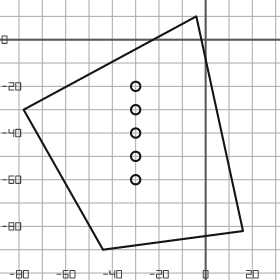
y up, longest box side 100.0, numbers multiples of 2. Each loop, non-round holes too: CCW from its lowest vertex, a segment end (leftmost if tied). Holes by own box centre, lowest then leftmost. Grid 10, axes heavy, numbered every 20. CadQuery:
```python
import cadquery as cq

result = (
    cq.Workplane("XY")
    .moveTo(-44.0, -90.0)
    .lineTo(16.0, -82.0)
    .lineTo(-4.0, 10.0)
    .lineTo(-78.0, -30.0)
    .close()
    .moveTo(-30.0, -60.0)
    .circle(2.0)
    .moveTo(-30.0, -50.0)
    .circle(2.0)
    .moveTo(-30.0, -40.0)
    .circle(2.0)
    .moveTo(-30.0, -30.0)
    .circle(2.0)
    .moveTo(-30.0, -20.0)
    .circle(2.0)
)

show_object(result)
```